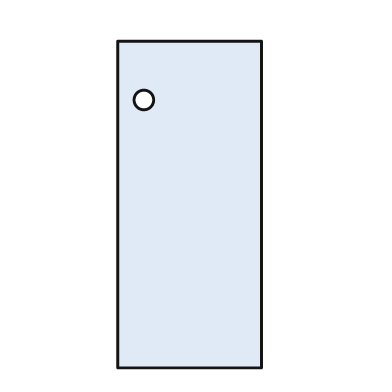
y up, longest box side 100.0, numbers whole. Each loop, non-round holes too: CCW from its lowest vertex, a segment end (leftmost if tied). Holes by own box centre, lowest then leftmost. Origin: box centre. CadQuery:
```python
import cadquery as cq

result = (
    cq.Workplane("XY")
    .moveTo(-22.0, -50.0)
    .lineTo(22.0, -50.0)
    .lineTo(22.0, 50.0)
    .lineTo(-22.0, 50.0)
    .close()
    .moveTo(-14.0, 32.0)
    .circle(3.0)
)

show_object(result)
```